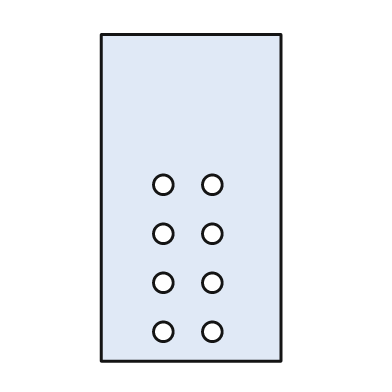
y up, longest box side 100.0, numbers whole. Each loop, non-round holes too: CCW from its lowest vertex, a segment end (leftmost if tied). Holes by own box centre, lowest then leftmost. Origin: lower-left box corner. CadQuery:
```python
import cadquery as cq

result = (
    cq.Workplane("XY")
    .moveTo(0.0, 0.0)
    .lineTo(55.0, 0.0)
    .lineTo(55.0, 100.0)
    .lineTo(0.0, 100.0)
    .close()
    .moveTo(19.0, 9.0)
    .circle(3.0)
    .moveTo(34.0, 9.0)
    .circle(3.0)
    .moveTo(19.0, 24.0)
    .circle(3.0)
    .moveTo(34.0, 24.0)
    .circle(3.0)
    .moveTo(19.0, 39.0)
    .circle(3.0)
    .moveTo(34.0, 39.0)
    .circle(3.0)
    .moveTo(19.0, 54.0)
    .circle(3.0)
    .moveTo(34.0, 54.0)
    .circle(3.0)
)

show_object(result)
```